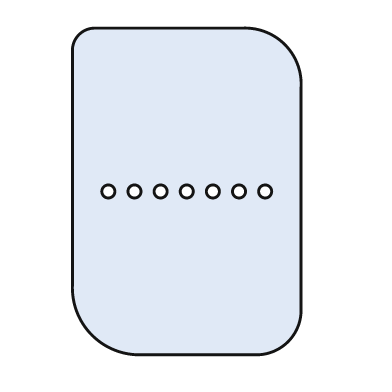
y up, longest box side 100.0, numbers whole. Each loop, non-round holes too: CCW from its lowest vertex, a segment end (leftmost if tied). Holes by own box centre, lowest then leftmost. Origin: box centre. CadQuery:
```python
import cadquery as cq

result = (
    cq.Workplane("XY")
    .moveTo(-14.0, -50.0)
    .lineTo(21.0, -50.0)
    .threePointArc((31.0, -46.0), (35.0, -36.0))
    .lineTo(35.0, 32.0)
    .threePointArc((30.0, 45.0), (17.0, 50.0))
    .lineTo(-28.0, 50.0)
    .threePointArc((-33.0, 48.0), (-35.0, 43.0))
    .lineTo(-35.0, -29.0)
    .threePointArc((-29.0, -44.0), (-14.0, -50.0))
    .close()
    .moveTo(-24.0, 0.0)
    .circle(2.0)
    .moveTo(-16.0, 0.0)
    .circle(2.0)
    .moveTo(-8.0, 0.0)
    .circle(2.0)
    .moveTo(0.0, 0.0)
    .circle(2.0)
    .moveTo(8.0, 0.0)
    .circle(2.0)
    .moveTo(16.0, 0.0)
    .circle(2.0)
    .moveTo(24.0, 0.0)
    .circle(2.0)
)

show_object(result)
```